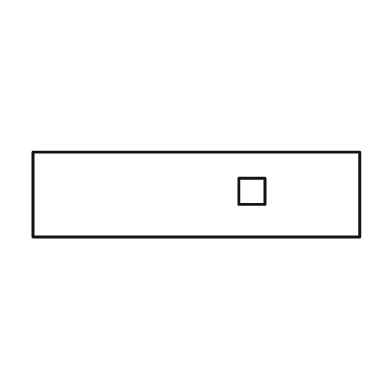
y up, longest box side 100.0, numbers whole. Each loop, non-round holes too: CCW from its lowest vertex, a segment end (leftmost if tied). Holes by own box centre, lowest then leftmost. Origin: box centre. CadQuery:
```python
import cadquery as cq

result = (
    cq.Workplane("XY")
    .moveTo(-50.0, -13.0)
    .lineTo(50.0, -13.0)
    .lineTo(50.0, 13.0)
    .lineTo(-50.0, 13.0)
    .close()
    .moveTo(13.0, -3.0)
    .lineTo(21.0, -3.0)
    .lineTo(21.0, 5.0)
    .lineTo(13.0, 5.0)
    .close()
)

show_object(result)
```